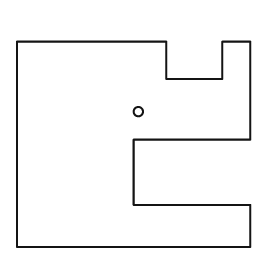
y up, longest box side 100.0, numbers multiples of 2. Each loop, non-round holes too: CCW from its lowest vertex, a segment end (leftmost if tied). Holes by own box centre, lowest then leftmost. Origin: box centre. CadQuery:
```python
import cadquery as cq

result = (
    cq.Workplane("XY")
    .moveTo(-50.0, -44.0)
    .lineTo(50.0, -44.0)
    .lineTo(50.0, -26.0)
    .lineTo(0.0, -26.0)
    .lineTo(0.0, 2.0)
    .lineTo(50.0, 2.0)
    .lineTo(50.0, 44.0)
    .lineTo(38.0, 44.0)
    .lineTo(38.0, 28.0)
    .lineTo(14.0, 28.0)
    .lineTo(14.0, 44.0)
    .lineTo(-50.0, 44.0)
    .close()
    .moveTo(2.0, 14.0)
    .circle(2.0)
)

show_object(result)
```